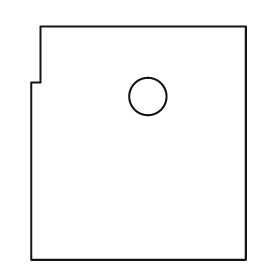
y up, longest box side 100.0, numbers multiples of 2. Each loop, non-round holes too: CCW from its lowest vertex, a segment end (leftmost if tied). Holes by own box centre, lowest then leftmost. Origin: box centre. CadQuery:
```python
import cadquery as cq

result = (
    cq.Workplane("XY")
    .moveTo(-46.0, -50.0)
    .lineTo(46.0, -50.0)
    .lineTo(46.0, 50.0)
    .lineTo(-42.0, 50.0)
    .lineTo(-42.0, 26.0)
    .lineTo(-46.0, 26.0)
    .close()
    .moveTo(4.0, 20.0)
    .circle(8.0)
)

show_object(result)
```